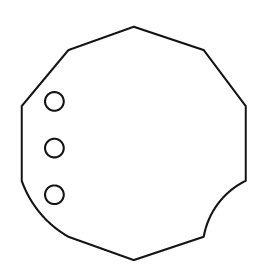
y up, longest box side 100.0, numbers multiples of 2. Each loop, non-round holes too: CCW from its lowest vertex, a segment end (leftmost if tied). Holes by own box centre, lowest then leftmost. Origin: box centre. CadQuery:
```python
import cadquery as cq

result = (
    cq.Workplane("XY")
    .moveTo(0.0, -50.0)
    .lineTo(30.0, -40.0)
    .threePointArc((36.0, -26.0), (48.0, -16.0))
    .lineTo(48.0, 16.0)
    .lineTo(30.0, 40.0)
    .lineTo(0.0, 50.0)
    .lineTo(-28.0, 40.0)
    .lineTo(-48.0, 16.0)
    .lineTo(-48.0, -16.0)
    .threePointArc((-40.0, -30.0), (-28.0, -40.0))
    .close()
    .moveTo(-34.0, -22.0)
    .circle(4.0)
    .moveTo(-34.0, -2.0)
    .circle(4.0)
    .moveTo(-34.0, 18.0)
    .circle(4.0)
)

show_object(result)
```